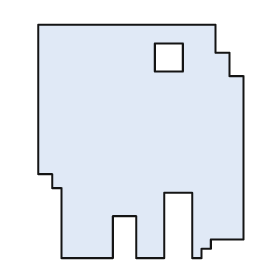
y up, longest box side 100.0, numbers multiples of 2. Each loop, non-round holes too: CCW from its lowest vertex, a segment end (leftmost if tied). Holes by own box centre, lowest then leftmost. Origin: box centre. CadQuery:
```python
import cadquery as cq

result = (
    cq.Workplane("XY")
    .moveTo(-34.0, -50.0)
    .lineTo(-12.0, -50.0)
    .lineTo(-12.0, -32.0)
    .lineTo(-2.0, -32.0)
    .lineTo(-2.0, -50.0)
    .lineTo(10.0, -50.0)
    .lineTo(10.0, -22.0)
    .lineTo(22.0, -22.0)
    .lineTo(22.0, -50.0)
    .lineTo(26.0, -50.0)
    .lineTo(26.0, -46.0)
    .lineTo(30.0, -46.0)
    .lineTo(30.0, -42.0)
    .lineTo(44.0, -42.0)
    .lineTo(44.0, 28.0)
    .lineTo(38.0, 28.0)
    .lineTo(38.0, 38.0)
    .lineTo(32.0, 38.0)
    .lineTo(32.0, 50.0)
    .lineTo(-44.0, 50.0)
    .lineTo(-44.0, -14.0)
    .lineTo(-38.0, -14.0)
    .lineTo(-38.0, -20.0)
    .lineTo(-34.0, -20.0)
    .close()
    .moveTo(6.0, 30.0)
    .lineTo(18.0, 30.0)
    .lineTo(18.0, 42.0)
    .lineTo(6.0, 42.0)
    .close()
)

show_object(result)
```